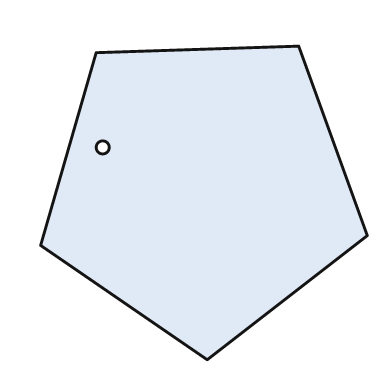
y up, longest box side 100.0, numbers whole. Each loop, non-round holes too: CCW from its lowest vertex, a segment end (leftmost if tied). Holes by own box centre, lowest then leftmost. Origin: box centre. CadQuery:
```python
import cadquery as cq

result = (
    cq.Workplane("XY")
    .moveTo(1.0, -48.0)
    .lineTo(50.0, -10.0)
    .lineTo(29.0, 48.0)
    .lineTo(-33.0, 46.0)
    .lineTo(-50.0, -13.0)
    .close()
    .moveTo(-31.0, 17.0)
    .circle(2.0)
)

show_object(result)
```